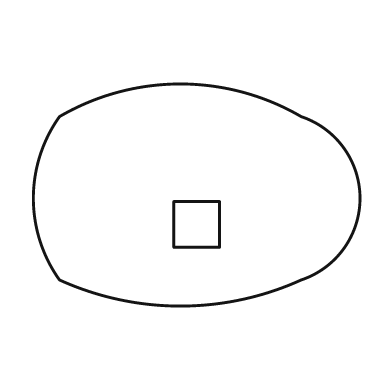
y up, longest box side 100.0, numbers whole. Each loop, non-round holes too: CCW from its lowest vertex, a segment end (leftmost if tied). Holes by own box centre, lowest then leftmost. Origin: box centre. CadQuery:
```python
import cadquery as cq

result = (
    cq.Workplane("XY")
    .moveTo(-42.0, -26.0)
    .threePointArc((-5.0, -34.0), (32.0, -26.0))
    .threePointArc((50.0, -1.0), (32.0, 24.0))
    .threePointArc((-5.0, 34.0), (-42.0, 24.0))
    .threePointArc((-50.0, -1.0), (-42.0, -26.0))
    .close()
    .moveTo(-7.0, -16.0)
    .lineTo(7.0, -16.0)
    .lineTo(7.0, -2.0)
    .lineTo(-7.0, -2.0)
    .close()
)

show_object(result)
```